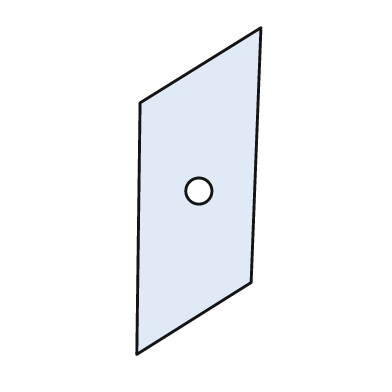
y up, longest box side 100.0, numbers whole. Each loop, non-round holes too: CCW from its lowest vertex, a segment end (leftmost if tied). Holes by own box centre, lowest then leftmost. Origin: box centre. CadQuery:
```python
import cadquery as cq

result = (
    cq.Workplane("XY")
    .moveTo(-19.0, -50.0)
    .lineTo(16.0, -28.0)
    .lineTo(19.0, 50.0)
    .lineTo(-18.0, 27.0)
    .close()
    .moveTo(0.0, 0.0)
    .circle(4.0)
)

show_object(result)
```